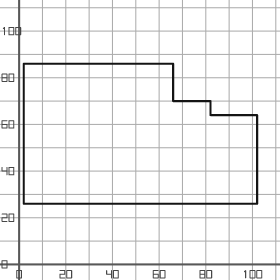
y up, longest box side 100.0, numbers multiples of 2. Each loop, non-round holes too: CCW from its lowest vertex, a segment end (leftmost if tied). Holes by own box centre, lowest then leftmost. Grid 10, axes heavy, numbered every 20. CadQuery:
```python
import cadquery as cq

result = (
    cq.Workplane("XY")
    .moveTo(2.0, 26.0)
    .lineTo(102.0, 26.0)
    .lineTo(102.0, 64.0)
    .lineTo(82.0, 64.0)
    .lineTo(82.0, 70.0)
    .lineTo(66.0, 70.0)
    .lineTo(66.0, 86.0)
    .lineTo(2.0, 86.0)
    .close()
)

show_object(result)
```